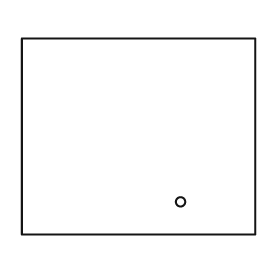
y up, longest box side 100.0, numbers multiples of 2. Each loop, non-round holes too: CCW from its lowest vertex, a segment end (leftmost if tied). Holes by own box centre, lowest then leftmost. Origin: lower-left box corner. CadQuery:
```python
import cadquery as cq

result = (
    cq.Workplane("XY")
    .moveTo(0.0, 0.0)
    .lineTo(100.0, 0.0)
    .lineTo(100.0, 84.0)
    .lineTo(0.0, 84.0)
    .close()
    .moveTo(68.0, 14.0)
    .circle(2.0)
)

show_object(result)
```